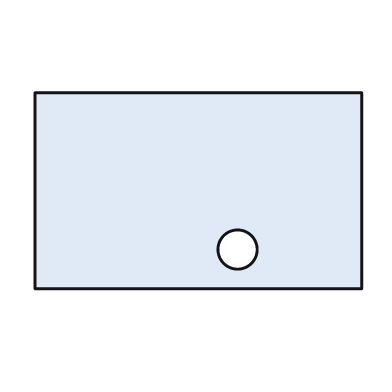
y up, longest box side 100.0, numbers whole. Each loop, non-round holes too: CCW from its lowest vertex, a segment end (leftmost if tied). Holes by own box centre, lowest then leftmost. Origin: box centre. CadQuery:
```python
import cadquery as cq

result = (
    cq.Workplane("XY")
    .moveTo(-50.0, -30.0)
    .lineTo(50.0, -30.0)
    .lineTo(50.0, 30.0)
    .lineTo(-50.0, 30.0)
    .close()
    .moveTo(12.0, -18.0)
    .circle(6.0)
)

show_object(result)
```